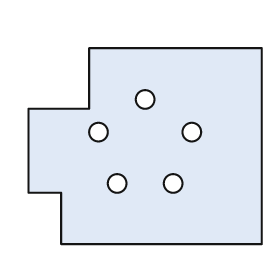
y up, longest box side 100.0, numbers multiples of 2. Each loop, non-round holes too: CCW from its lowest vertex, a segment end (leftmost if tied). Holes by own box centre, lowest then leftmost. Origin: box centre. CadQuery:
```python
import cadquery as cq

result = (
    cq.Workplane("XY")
    .moveTo(-36.0, -42.0)
    .lineTo(50.0, -42.0)
    .lineTo(50.0, 42.0)
    .lineTo(-24.0, 42.0)
    .lineTo(-24.0, 16.0)
    .lineTo(-50.0, 16.0)
    .lineTo(-50.0, -20.0)
    .lineTo(-36.0, -20.0)
    .close()
    .moveTo(-12.0, -16.0)
    .circle(4.0)
    .moveTo(12.0, -16.0)
    .circle(4.0)
    .moveTo(-20.0, 6.0)
    .circle(4.0)
    .moveTo(20.0, 6.0)
    .circle(4.0)
    .moveTo(0.0, 20.0)
    .circle(4.0)
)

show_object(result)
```